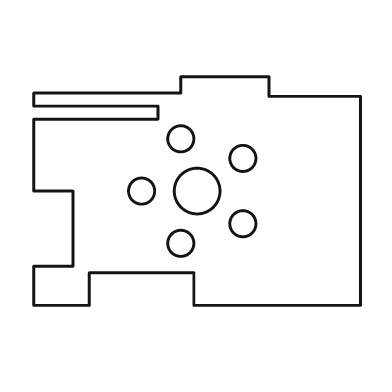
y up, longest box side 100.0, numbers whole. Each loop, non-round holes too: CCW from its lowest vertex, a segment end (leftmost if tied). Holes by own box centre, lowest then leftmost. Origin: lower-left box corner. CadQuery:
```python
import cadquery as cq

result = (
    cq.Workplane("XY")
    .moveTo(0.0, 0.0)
    .lineTo(17.0, 0.0)
    .lineTo(17.0, 10.0)
    .lineTo(49.0, 10.0)
    .lineTo(49.0, 0.0)
    .lineTo(100.0, 0.0)
    .lineTo(100.0, 64.0)
    .lineTo(72.0, 64.0)
    .lineTo(72.0, 70.0)
    .lineTo(45.0, 70.0)
    .lineTo(45.0, 65.0)
    .lineTo(0.0, 65.0)
    .lineTo(0.0, 61.0)
    .lineTo(38.0, 61.0)
    .lineTo(38.0, 57.0)
    .lineTo(0.0, 57.0)
    .lineTo(0.0, 35.0)
    .lineTo(12.0, 35.0)
    .lineTo(12.0, 12.0)
    .lineTo(0.0, 12.0)
    .close()
    .moveTo(45.0, 19.0)
    .circle(4.0)
    .moveTo(64.0, 25.0)
    .circle(4.0)
    .moveTo(33.0, 35.0)
    .circle(4.0)
    .moveTo(50.0, 35.0)
    .circle(7.0)
    .moveTo(64.0, 45.0)
    .circle(4.0)
    .moveTo(45.0, 51.0)
    .circle(4.0)
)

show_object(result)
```